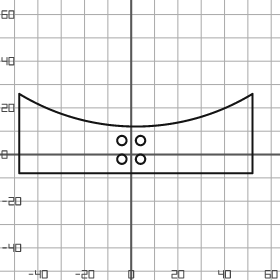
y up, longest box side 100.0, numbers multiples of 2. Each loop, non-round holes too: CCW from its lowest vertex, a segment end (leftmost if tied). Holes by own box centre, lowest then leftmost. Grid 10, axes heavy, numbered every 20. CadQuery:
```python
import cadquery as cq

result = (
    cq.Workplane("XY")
    .moveTo(-48.0, -8.0)
    .lineTo(52.0, -8.0)
    .lineTo(52.0, 26.0)
    .threePointArc((2.0, 12.0), (-48.0, 26.0))
    .close()
    .moveTo(-4.0, -2.0)
    .circle(2.0)
    .moveTo(4.0, -2.0)
    .circle(2.0)
    .moveTo(-4.0, 6.0)
    .circle(2.0)
    .moveTo(4.0, 6.0)
    .circle(2.0)
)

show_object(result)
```